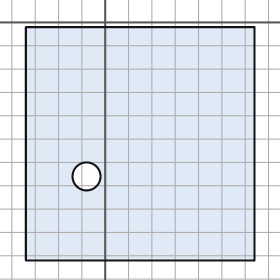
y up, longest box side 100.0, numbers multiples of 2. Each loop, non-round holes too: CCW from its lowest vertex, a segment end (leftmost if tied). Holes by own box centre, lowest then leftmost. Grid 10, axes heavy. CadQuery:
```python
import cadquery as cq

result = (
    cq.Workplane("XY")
    .moveTo(-34.0, -102.0)
    .lineTo(64.0, -102.0)
    .lineTo(64.0, -2.0)
    .lineTo(-34.0, -2.0)
    .close()
    .moveTo(-8.0, -66.0)
    .circle(6.0)
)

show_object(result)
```